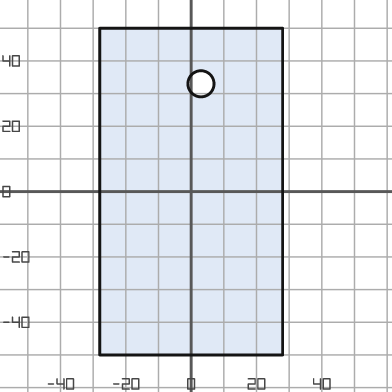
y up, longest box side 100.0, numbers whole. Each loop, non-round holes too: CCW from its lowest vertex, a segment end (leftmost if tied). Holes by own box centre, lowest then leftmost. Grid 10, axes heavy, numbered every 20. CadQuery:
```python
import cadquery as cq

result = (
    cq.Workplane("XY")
    .moveTo(-28.0, -50.0)
    .lineTo(28.0, -50.0)
    .lineTo(28.0, 50.0)
    .lineTo(-28.0, 50.0)
    .close()
    .moveTo(3.0, 33.0)
    .circle(4.0)
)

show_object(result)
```